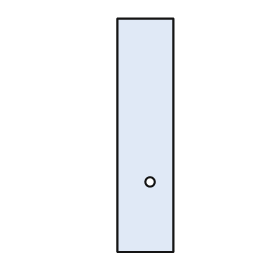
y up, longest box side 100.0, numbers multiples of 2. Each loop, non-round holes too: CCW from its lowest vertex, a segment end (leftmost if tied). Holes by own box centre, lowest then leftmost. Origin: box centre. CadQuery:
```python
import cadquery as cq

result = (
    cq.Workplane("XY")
    .moveTo(-12.0, -50.0)
    .lineTo(12.0, -50.0)
    .lineTo(12.0, 50.0)
    .lineTo(-12.0, 50.0)
    .close()
    .moveTo(2.0, -20.0)
    .circle(2.0)
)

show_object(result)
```